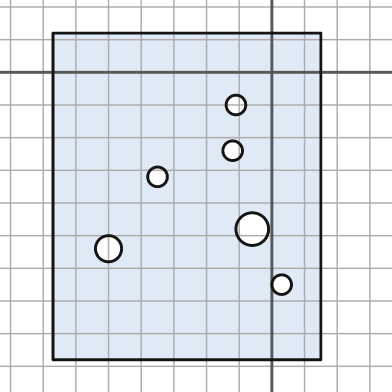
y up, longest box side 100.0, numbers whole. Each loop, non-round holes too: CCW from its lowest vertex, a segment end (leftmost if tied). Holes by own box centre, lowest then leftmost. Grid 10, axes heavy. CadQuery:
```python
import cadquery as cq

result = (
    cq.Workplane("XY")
    .moveTo(-67.0, -88.0)
    .lineTo(15.0, -88.0)
    .lineTo(15.0, 12.0)
    .lineTo(-67.0, 12.0)
    .close()
    .moveTo(3.0, -65.0)
    .circle(3.0)
    .moveTo(-50.0, -54.0)
    .circle(4.0)
    .moveTo(-6.0, -48.0)
    .circle(5.0)
    .moveTo(-35.0, -32.0)
    .circle(3.0)
    .moveTo(-12.0, -24.0)
    .circle(3.0)
    .moveTo(-11.0, -10.0)
    .circle(3.0)
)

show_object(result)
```